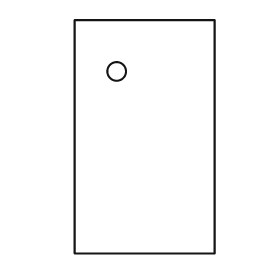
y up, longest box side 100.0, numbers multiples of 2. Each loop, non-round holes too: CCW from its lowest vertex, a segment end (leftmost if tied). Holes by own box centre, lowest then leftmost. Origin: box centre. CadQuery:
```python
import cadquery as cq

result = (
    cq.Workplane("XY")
    .moveTo(-30.0, -50.0)
    .lineTo(30.0, -50.0)
    .lineTo(30.0, 50.0)
    .lineTo(-30.0, 50.0)
    .close()
    .moveTo(-12.0, 28.0)
    .circle(4.0)
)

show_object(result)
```